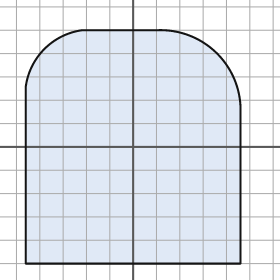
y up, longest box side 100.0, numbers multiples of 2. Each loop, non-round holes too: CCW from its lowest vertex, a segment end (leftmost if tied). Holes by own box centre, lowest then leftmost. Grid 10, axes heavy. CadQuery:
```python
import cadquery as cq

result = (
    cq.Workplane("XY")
    .moveTo(-46.0, -50.0)
    .lineTo(46.0, -50.0)
    .lineTo(46.0, 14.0)
    .threePointArc((36.0, 40.0), (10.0, 50.0))
    .lineTo(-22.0, 50.0)
    .threePointArc((-38.0, 42.0), (-46.0, 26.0))
    .close()
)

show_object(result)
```